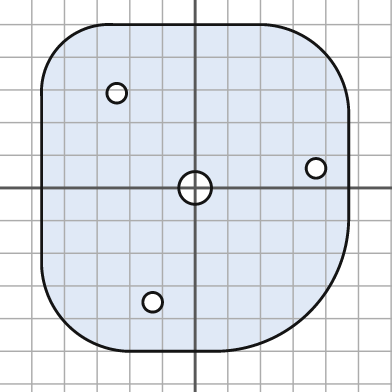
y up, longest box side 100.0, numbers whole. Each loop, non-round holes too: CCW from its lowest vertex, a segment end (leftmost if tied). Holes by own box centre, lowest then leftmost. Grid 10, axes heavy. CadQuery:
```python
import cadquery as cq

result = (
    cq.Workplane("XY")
    .moveTo(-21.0, -50.0)
    .lineTo(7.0, -50.0)
    .threePointArc((35.0, -38.0), (47.0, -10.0))
    .lineTo(47.0, 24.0)
    .threePointArc((39.0, 42.0), (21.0, 50.0))
    .lineTo(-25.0, 50.0)
    .threePointArc((-41.0, 44.0), (-47.0, 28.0))
    .lineTo(-47.0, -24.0)
    .threePointArc((-39.0, -42.0), (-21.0, -50.0))
    .close()
    .moveTo(-13.0, -35.0)
    .circle(3.0)
    .moveTo(0.0, 0.0)
    .circle(5.0)
    .moveTo(37.0, 6.0)
    .circle(3.0)
    .moveTo(-24.0, 29.0)
    .circle(3.0)
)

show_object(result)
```